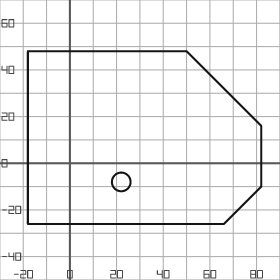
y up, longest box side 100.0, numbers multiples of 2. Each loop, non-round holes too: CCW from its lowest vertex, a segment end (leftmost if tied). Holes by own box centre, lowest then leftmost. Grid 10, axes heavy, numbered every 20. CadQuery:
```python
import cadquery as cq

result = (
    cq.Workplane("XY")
    .moveTo(-18.0, -26.0)
    .lineTo(66.0, -26.0)
    .lineTo(82.0, -10.0)
    .lineTo(82.0, 16.0)
    .lineTo(50.0, 48.0)
    .lineTo(-18.0, 48.0)
    .close()
    .moveTo(22.0, -8.0)
    .circle(4.0)
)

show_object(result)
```